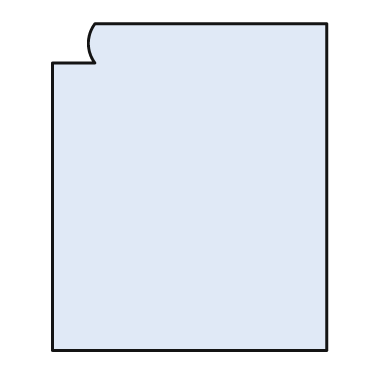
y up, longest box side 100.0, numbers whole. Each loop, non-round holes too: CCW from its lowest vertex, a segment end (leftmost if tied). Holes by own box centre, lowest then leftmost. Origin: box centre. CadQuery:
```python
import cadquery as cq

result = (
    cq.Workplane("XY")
    .moveTo(-42.0, -50.0)
    .lineTo(42.0, -50.0)
    .lineTo(42.0, 50.0)
    .lineTo(-29.0, 50.0)
    .threePointArc((-31.0, 44.0), (-29.0, 38.0))
    .lineTo(-42.0, 38.0)
    .close()
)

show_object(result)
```